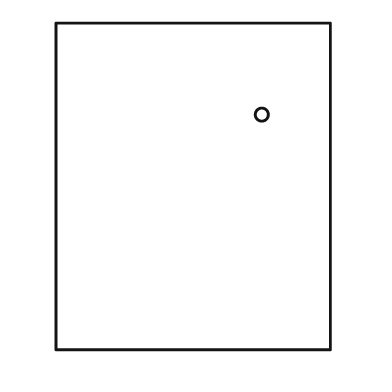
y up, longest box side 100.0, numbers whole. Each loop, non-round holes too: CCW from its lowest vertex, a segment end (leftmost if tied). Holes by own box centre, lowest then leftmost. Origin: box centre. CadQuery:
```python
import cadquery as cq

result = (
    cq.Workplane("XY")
    .moveTo(-42.0, -50.0)
    .lineTo(42.0, -50.0)
    .lineTo(42.0, 50.0)
    .lineTo(-42.0, 50.0)
    .close()
    .moveTo(21.0, 22.0)
    .circle(2.0)
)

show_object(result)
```